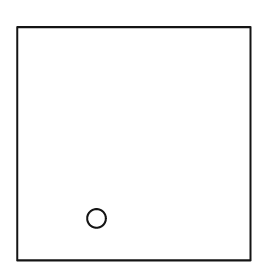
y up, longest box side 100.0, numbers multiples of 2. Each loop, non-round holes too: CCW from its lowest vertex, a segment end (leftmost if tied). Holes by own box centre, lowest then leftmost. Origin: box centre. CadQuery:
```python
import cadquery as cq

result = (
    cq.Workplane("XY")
    .moveTo(-50.0, -50.0)
    .lineTo(50.0, -50.0)
    .lineTo(50.0, 50.0)
    .lineTo(-50.0, 50.0)
    .close()
    .moveTo(-16.0, -32.0)
    .circle(4.0)
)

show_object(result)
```